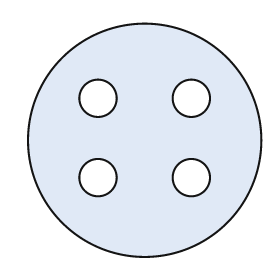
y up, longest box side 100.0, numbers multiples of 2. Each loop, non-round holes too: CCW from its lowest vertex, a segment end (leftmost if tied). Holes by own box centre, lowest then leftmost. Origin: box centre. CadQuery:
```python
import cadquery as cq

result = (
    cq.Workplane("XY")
    .moveTo(0.0, 0.0)
    .circle(50.0)
    .moveTo(-20.0, -16.0)
    .circle(8.0)
    .moveTo(20.0, -16.0)
    .circle(8.0)
    .moveTo(-20.0, 18.0)
    .circle(8.0)
    .moveTo(20.0, 18.0)
    .circle(8.0)
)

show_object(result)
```